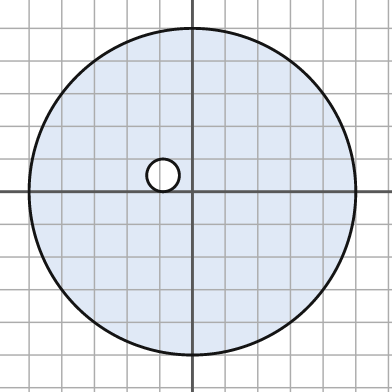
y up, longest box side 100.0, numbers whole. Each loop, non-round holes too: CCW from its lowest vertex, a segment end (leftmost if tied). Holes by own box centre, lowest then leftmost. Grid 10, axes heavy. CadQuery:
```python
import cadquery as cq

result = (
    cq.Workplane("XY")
    .moveTo(0.0, 0.0)
    .circle(50.0)
    .moveTo(-9.0, 5.0)
    .circle(5.0)
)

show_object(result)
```